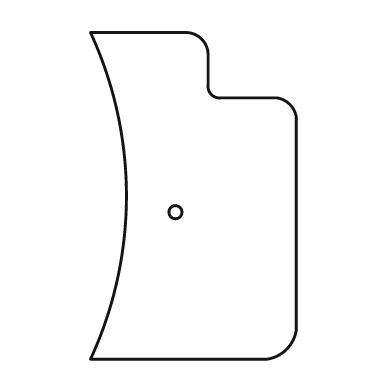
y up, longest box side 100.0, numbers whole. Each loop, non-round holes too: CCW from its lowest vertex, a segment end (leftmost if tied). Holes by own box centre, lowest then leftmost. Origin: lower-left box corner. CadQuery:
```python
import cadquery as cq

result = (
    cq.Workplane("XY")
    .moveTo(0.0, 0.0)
    .lineTo(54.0, 0.0)
    .threePointArc((60.0, 3.0), (63.0, 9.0))
    .lineTo(63.0, 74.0)
    .threePointArc((61.0, 78.0), (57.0, 80.0))
    .lineTo(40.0, 80.0)
    .threePointArc((37.0, 81.0), (36.0, 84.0))
    .lineTo(36.0, 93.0)
    .threePointArc((34.0, 98.0), (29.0, 100.0))
    .lineTo(0.0, 100.0)
    .threePointArc((11.0, 50.0), (0.0, 0.0))
    .close()
    .moveTo(26.0, 45.0)
    .circle(2.0)
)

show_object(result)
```